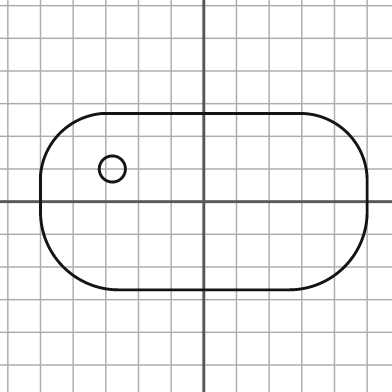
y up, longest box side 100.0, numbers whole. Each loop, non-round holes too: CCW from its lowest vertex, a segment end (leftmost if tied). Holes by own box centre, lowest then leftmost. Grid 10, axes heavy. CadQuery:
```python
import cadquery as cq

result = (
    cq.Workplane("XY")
    .moveTo(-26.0, -27.0)
    .lineTo(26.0, -27.0)
    .threePointArc((43.0, -20.0), (50.0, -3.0))
    .lineTo(50.0, 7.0)
    .threePointArc((44.0, 21.0), (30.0, 27.0))
    .lineTo(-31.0, 27.0)
    .threePointArc((-44.0, 21.0), (-50.0, 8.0))
    .lineTo(-50.0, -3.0)
    .threePointArc((-43.0, -20.0), (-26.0, -27.0))
    .close()
    .moveTo(-28.0, 10.0)
    .circle(4.0)
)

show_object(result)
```